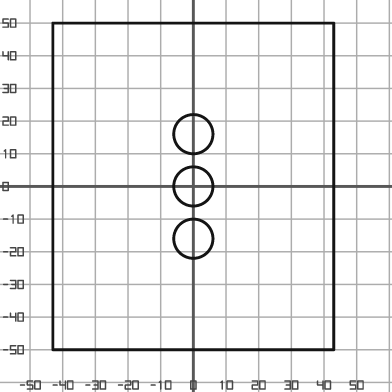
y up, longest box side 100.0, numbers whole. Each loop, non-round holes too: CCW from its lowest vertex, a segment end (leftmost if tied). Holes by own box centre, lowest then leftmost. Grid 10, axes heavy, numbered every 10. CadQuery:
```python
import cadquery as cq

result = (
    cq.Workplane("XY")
    .moveTo(-43.0, -50.0)
    .lineTo(43.0, -50.0)
    .lineTo(43.0, 50.0)
    .lineTo(-43.0, 50.0)
    .close()
    .moveTo(0.0, -16.0)
    .circle(6.0)
    .moveTo(0.0, 0.0)
    .circle(6.0)
    .moveTo(0.0, 16.0)
    .circle(6.0)
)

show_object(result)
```